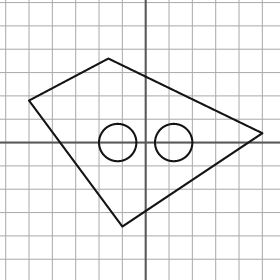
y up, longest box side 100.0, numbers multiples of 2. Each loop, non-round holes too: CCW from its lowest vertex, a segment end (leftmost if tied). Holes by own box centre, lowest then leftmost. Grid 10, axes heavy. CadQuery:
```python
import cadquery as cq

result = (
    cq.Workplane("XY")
    .moveTo(-10.0, -36.0)
    .lineTo(50.0, 4.0)
    .lineTo(-16.0, 36.0)
    .lineTo(-50.0, 18.0)
    .close()
    .moveTo(-12.0, 0.0)
    .circle(8.0)
    .moveTo(12.0, 0.0)
    .circle(8.0)
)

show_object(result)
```